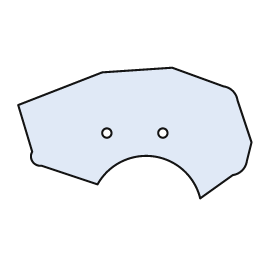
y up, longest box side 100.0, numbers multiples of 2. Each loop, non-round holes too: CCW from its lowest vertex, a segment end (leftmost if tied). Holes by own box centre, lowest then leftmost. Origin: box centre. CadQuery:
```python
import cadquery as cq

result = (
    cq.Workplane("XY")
    .moveTo(28.0, -28.0)
    .lineTo(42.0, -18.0)
    .threePointArc((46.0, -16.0), (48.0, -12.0))
    .lineTo(50.0, -4.0)
    .lineTo(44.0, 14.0)
    .threePointArc((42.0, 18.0), (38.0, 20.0))
    .lineTo(16.0, 28.0)
    .lineTo(-14.0, 26.0)
    .lineTo(-50.0, 12.0)
    .lineTo(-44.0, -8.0)
    .threePointArc((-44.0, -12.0), (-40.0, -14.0))
    .lineTo(-16.0, -22.0)
    .threePointArc((8.0, -10.0), (28.0, -28.0))
    .close()
    .moveTo(-12.0, 0.0)
    .circle(2.0)
    .moveTo(12.0, 0.0)
    .circle(2.0)
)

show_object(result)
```